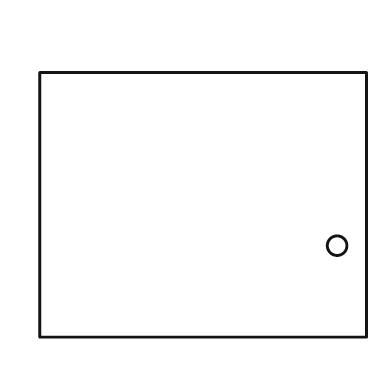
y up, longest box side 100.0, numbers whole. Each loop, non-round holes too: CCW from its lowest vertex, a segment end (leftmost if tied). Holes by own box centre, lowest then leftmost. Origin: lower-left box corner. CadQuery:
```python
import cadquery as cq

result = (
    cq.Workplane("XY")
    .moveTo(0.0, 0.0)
    .lineTo(100.0, 0.0)
    .lineTo(100.0, 81.0)
    .lineTo(0.0, 81.0)
    .close()
    .moveTo(91.0, 28.0)
    .circle(3.0)
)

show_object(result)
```